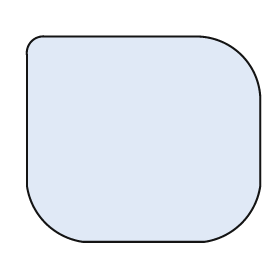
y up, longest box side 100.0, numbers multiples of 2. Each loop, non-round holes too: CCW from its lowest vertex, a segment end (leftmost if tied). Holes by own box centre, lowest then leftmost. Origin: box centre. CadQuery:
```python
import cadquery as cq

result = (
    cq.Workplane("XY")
    .moveTo(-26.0, -44.0)
    .lineTo(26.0, -44.0)
    .threePointArc((42.0, -36.0), (50.0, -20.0))
    .lineTo(50.0, 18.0)
    .threePointArc((42.0, 36.0), (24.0, 44.0))
    .lineTo(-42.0, 44.0)
    .threePointArc((-48.0, 42.0), (-50.0, 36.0))
    .lineTo(-50.0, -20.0)
    .threePointArc((-42.0, -36.0), (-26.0, -44.0))
    .close()
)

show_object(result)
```